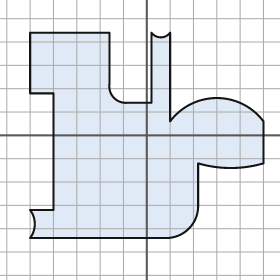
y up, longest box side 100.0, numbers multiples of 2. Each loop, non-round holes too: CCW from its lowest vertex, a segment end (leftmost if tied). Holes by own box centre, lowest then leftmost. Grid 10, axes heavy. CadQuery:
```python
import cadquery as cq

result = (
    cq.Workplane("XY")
    .moveTo(-50.0, -44.0)
    .lineTo(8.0, -44.0)
    .threePointArc((18.0, -40.0), (22.0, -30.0))
    .lineTo(22.0, -12.0)
    .threePointArc((36.0, -14.0), (50.0, -12.0))
    .lineTo(50.0, 6.0)
    .threePointArc((30.0, 16.0), (10.0, 6.0))
    .lineTo(10.0, 44.0)
    .threePointArc((6.0, 42.0), (2.0, 44.0))
    .lineTo(2.0, 14.0)
    .lineTo(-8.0, 14.0)
    .threePointArc((-14.0, 16.0), (-16.0, 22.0))
    .lineTo(-16.0, 44.0)
    .lineTo(-50.0, 44.0)
    .lineTo(-50.0, 18.0)
    .lineTo(-40.0, 18.0)
    .lineTo(-40.0, -32.0)
    .lineTo(-50.0, -32.0)
    .threePointArc((-48.0, -38.0), (-50.0, -44.0))
    .close()
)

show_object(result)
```